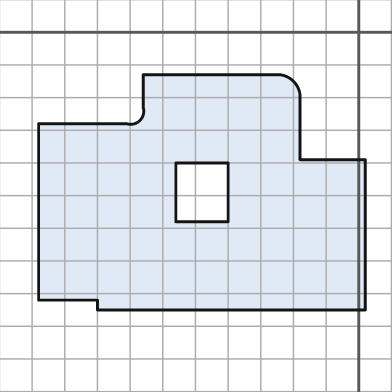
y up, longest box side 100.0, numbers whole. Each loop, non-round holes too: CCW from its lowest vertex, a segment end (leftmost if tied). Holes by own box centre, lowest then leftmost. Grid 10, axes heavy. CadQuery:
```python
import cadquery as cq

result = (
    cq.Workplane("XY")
    .moveTo(-80.0, -85.0)
    .lineTo(2.0, -85.0)
    .lineTo(2.0, -39.0)
    .lineTo(-18.0, -39.0)
    .lineTo(-18.0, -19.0)
    .threePointArc((-20.0, -15.0), (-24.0, -13.0))
    .lineTo(-66.0, -13.0)
    .lineTo(-66.0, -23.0)
    .threePointArc((-67.0, -27.0), (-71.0, -28.0))
    .lineTo(-98.0, -28.0)
    .lineTo(-98.0, -82.0)
    .lineTo(-80.0, -82.0)
    .close()
    .moveTo(-56.0, -58.0)
    .lineTo(-40.0, -58.0)
    .lineTo(-40.0, -40.0)
    .lineTo(-56.0, -40.0)
    .close()
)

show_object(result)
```